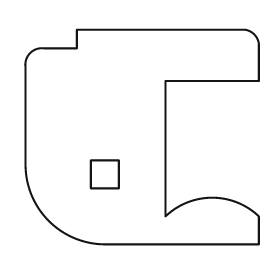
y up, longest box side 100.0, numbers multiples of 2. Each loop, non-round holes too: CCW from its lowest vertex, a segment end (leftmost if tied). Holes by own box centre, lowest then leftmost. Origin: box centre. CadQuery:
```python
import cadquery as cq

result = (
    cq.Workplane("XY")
    .moveTo(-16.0, -46.0)
    .lineTo(50.0, -46.0)
    .lineTo(50.0, -34.0)
    .threePointArc((30.0, -26.0), (10.0, -34.0))
    .lineTo(10.0, 24.0)
    .lineTo(50.0, 24.0)
    .lineTo(50.0, 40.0)
    .threePointArc((48.0, 44.0), (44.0, 46.0))
    .lineTo(-28.0, 46.0)
    .lineTo(-28.0, 38.0)
    .lineTo(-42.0, 38.0)
    .threePointArc((-48.0, 36.0), (-50.0, 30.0))
    .lineTo(-50.0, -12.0)
    .threePointArc((-40.0, -36.0), (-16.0, -46.0))
    .close()
    .moveTo(-22.0, -22.0)
    .lineTo(-10.0, -22.0)
    .lineTo(-10.0, -10.0)
    .lineTo(-22.0, -10.0)
    .close()
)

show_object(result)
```